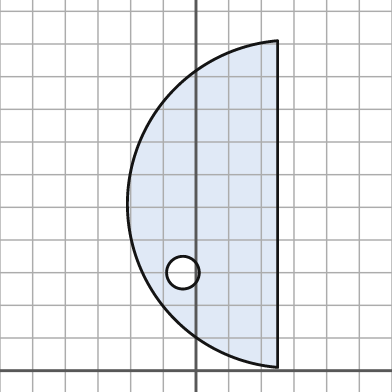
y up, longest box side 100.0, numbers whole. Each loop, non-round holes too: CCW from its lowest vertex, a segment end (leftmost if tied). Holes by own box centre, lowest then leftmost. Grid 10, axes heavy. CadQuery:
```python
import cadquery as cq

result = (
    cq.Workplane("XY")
    .moveTo(25.0, 1.0)
    .lineTo(25.0, 101.0)
    .threePointArc((-21.0, 51.0), (25.0, 1.0))
    .close()
    .moveTo(-4.0, 30.0)
    .circle(5.0)
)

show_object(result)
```